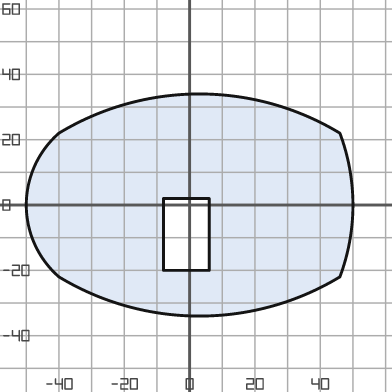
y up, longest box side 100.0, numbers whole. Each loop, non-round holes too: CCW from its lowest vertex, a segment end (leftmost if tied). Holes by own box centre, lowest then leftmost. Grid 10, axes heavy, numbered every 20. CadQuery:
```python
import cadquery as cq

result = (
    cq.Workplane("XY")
    .moveTo(-40.0, -22.0)
    .threePointArc((3.0, -34.0), (46.0, -22.0))
    .threePointArc((50.0, 0.0), (46.0, 22.0))
    .threePointArc((3.0, 34.0), (-40.0, 22.0))
    .threePointArc((-50.0, 0.0), (-40.0, -22.0))
    .close()
    .moveTo(-8.0, -20.0)
    .lineTo(6.0, -20.0)
    .lineTo(6.0, 2.0)
    .lineTo(-8.0, 2.0)
    .close()
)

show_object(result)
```